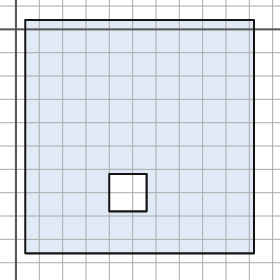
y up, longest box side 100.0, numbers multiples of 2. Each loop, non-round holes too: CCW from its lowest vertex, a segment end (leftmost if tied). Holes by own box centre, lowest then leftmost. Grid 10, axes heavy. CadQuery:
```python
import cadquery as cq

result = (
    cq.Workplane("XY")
    .moveTo(4.0, -96.0)
    .lineTo(102.0, -96.0)
    .lineTo(102.0, 4.0)
    .lineTo(4.0, 4.0)
    .close()
    .moveTo(40.0, -78.0)
    .lineTo(56.0, -78.0)
    .lineTo(56.0, -62.0)
    .lineTo(40.0, -62.0)
    .close()
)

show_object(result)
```